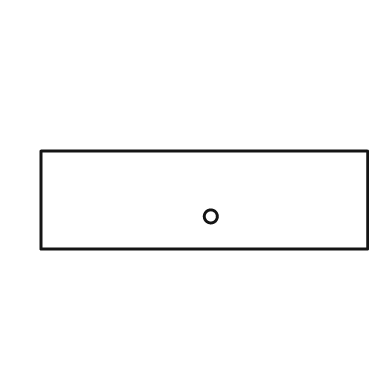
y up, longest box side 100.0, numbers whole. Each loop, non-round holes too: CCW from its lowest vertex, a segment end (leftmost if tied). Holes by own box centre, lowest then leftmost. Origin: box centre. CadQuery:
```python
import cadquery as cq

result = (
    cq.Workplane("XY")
    .moveTo(-50.0, -15.0)
    .lineTo(50.0, -15.0)
    .lineTo(50.0, 15.0)
    .lineTo(-50.0, 15.0)
    .close()
    .moveTo(2.0, -5.0)
    .circle(2.0)
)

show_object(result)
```